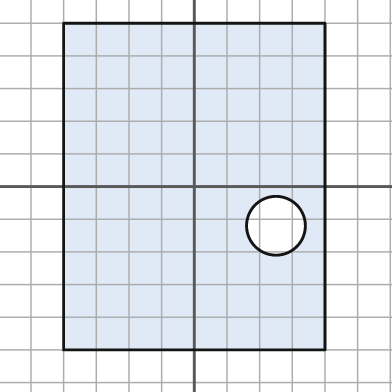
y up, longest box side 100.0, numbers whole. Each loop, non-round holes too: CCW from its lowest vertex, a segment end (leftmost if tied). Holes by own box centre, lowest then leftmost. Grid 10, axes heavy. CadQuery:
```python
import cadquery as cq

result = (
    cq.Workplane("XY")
    .moveTo(-40.0, -50.0)
    .lineTo(40.0, -50.0)
    .lineTo(40.0, 50.0)
    .lineTo(-40.0, 50.0)
    .close()
    .moveTo(25.0, -12.0)
    .circle(9.0)
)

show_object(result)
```